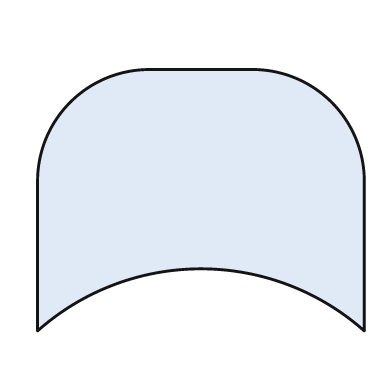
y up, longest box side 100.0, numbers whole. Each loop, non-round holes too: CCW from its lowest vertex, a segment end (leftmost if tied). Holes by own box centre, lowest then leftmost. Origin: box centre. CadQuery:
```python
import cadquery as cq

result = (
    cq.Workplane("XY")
    .moveTo(-50.0, -40.0)
    .threePointArc((0.0, -21.0), (50.0, -40.0))
    .lineTo(50.0, 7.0)
    .threePointArc((40.0, 30.0), (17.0, 40.0))
    .lineTo(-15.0, 40.0)
    .threePointArc((-40.0, 30.0), (-50.0, 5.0))
    .close()
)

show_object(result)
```